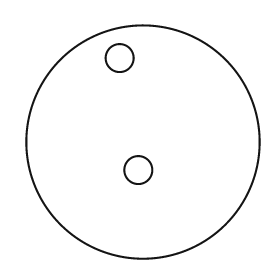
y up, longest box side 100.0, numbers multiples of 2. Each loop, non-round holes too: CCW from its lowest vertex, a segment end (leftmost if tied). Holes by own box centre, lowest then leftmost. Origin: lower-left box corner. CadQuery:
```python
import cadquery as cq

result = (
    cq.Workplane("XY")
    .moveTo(50.0, 50.0)
    .circle(50.0)
    .moveTo(48.0, 38.0)
    .circle(6.0)
    .moveTo(40.0, 86.0)
    .circle(6.0)
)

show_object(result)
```